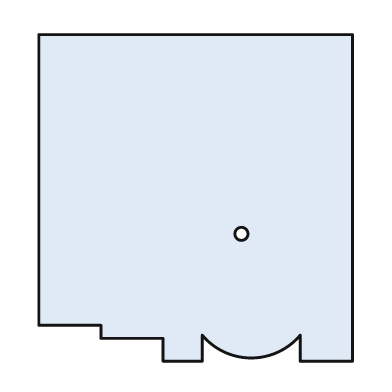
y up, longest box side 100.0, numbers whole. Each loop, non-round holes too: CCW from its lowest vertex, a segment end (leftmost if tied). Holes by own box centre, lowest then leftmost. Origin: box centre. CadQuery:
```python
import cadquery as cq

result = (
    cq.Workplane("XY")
    .moveTo(-10.0, -50.0)
    .lineTo(2.0, -50.0)
    .lineTo(2.0, -42.0)
    .threePointArc((17.0, -49.0), (32.0, -42.0))
    .lineTo(32.0, -50.0)
    .lineTo(48.0, -50.0)
    .lineTo(48.0, 50.0)
    .lineTo(-48.0, 50.0)
    .lineTo(-48.0, -39.0)
    .lineTo(-29.0, -39.0)
    .lineTo(-29.0, -43.0)
    .lineTo(-10.0, -43.0)
    .close()
    .moveTo(14.0, -11.0)
    .circle(2.0)
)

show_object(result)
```